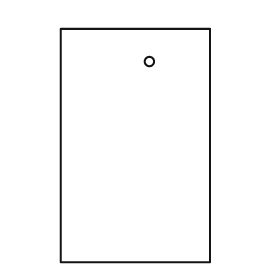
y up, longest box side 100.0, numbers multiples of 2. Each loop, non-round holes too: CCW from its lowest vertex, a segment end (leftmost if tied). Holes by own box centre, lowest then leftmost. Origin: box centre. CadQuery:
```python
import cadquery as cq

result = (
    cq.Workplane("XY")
    .moveTo(-32.0, -50.0)
    .lineTo(32.0, -50.0)
    .lineTo(32.0, 50.0)
    .lineTo(-32.0, 50.0)
    .close()
    .moveTo(6.0, 36.0)
    .circle(2.0)
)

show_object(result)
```